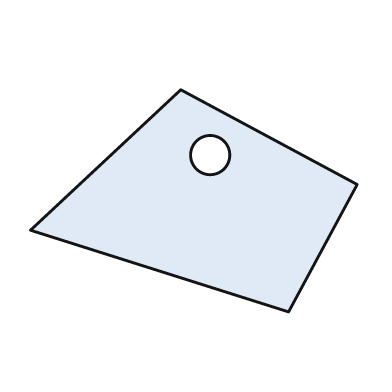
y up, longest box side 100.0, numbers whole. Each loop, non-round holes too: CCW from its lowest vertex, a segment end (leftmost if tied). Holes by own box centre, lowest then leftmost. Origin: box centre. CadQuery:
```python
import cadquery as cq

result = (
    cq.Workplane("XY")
    .moveTo(29.0, -34.0)
    .lineTo(50.0, 5.0)
    .lineTo(-4.0, 34.0)
    .lineTo(-50.0, -9.0)
    .close()
    .moveTo(5.0, 14.0)
    .circle(6.0)
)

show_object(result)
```